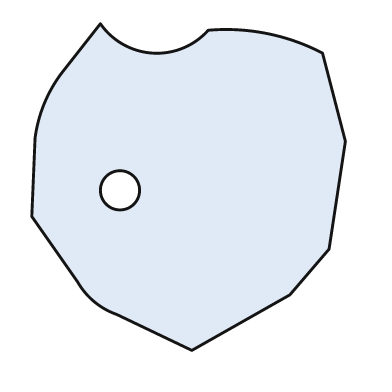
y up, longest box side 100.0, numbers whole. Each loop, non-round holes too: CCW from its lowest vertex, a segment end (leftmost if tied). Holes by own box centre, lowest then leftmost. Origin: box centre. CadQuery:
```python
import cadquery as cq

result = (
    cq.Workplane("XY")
    .moveTo(1.0, -50.0)
    .lineTo(31.0, -33.0)
    .lineTo(43.0, -19.0)
    .lineTo(48.0, 14.0)
    .lineTo(41.0, 41.0)
    .threePointArc((24.0, 47.0), (6.0, 48.0))
    .threePointArc((-11.0, 41.0), (-27.0, 50.0))
    .lineTo(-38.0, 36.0)
    .threePointArc((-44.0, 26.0), (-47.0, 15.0))
    .lineTo(-48.0, -9.0)
    .lineTo(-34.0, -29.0)
    .threePointArc((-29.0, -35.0), (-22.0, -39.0))
    .close()
    .moveTo(-21.0, -1.0)
    .circle(6.0)
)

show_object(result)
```